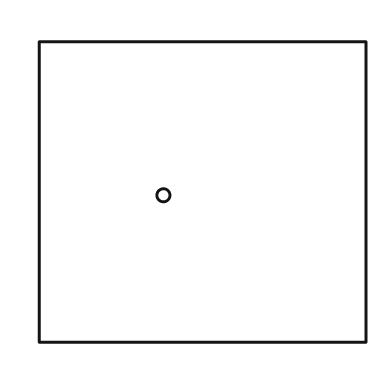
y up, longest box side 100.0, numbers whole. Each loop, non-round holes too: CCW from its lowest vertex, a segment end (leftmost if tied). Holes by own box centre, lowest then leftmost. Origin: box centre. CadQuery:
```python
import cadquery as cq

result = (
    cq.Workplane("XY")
    .moveTo(-50.0, -46.0)
    .lineTo(50.0, -46.0)
    .lineTo(50.0, 46.0)
    .lineTo(-50.0, 46.0)
    .close()
    .moveTo(-12.0, -1.0)
    .circle(2.0)
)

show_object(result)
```